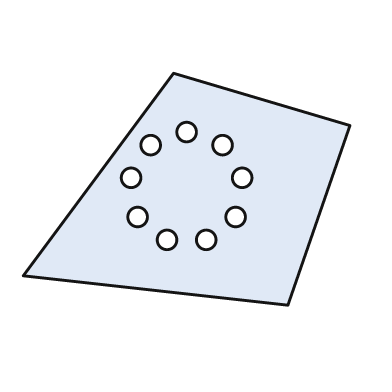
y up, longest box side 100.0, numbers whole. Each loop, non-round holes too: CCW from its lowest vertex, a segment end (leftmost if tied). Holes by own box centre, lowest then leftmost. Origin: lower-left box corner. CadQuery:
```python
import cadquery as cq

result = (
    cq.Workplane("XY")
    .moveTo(81.0, 0.0)
    .lineTo(100.0, 55.0)
    .lineTo(46.0, 71.0)
    .lineTo(0.0, 9.0)
    .close()
    .moveTo(44.0, 20.0)
    .circle(3.0)
    .moveTo(56.0, 20.0)
    .circle(3.0)
    .moveTo(35.0, 27.0)
    .circle(3.0)
    .moveTo(65.0, 27.0)
    .circle(3.0)
    .moveTo(33.0, 39.0)
    .circle(3.0)
    .moveTo(67.0, 39.0)
    .circle(3.0)
    .moveTo(39.0, 49.0)
    .circle(3.0)
    .moveTo(61.0, 49.0)
    .circle(3.0)
    .moveTo(50.0, 53.0)
    .circle(3.0)
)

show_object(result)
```